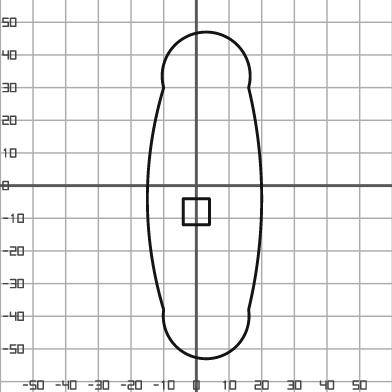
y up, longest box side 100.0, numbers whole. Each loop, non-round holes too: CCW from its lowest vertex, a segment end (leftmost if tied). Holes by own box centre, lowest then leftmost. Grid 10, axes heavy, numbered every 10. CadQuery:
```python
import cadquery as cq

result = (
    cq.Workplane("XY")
    .moveTo(-10.0, -38.0)
    .threePointArc((3.0, -53.0), (16.0, -38.0))
    .threePointArc((20.0, -4.0), (16.0, 30.0))
    .threePointArc((3.0, 47.0), (-10.0, 30.0))
    .threePointArc((-15.0, -4.0), (-10.0, -38.0))
    .close()
    .moveTo(-4.0, -12.0)
    .lineTo(4.0, -12.0)
    .lineTo(4.0, -4.0)
    .lineTo(-4.0, -4.0)
    .close()
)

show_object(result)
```